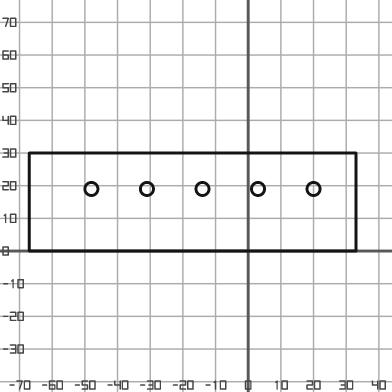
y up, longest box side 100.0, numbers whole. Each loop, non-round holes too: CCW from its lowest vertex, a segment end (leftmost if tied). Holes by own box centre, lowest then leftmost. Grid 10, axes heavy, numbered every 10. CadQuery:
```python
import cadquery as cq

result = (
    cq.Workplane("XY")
    .moveTo(-67.0, 0.0)
    .lineTo(33.0, 0.0)
    .lineTo(33.0, 30.0)
    .lineTo(-67.0, 30.0)
    .close()
    .moveTo(-48.0, 19.0)
    .circle(2.0)
    .moveTo(-31.0, 19.0)
    .circle(2.0)
    .moveTo(-14.0, 19.0)
    .circle(2.0)
    .moveTo(3.0, 19.0)
    .circle(2.0)
    .moveTo(20.0, 19.0)
    .circle(2.0)
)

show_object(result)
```